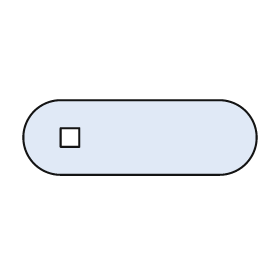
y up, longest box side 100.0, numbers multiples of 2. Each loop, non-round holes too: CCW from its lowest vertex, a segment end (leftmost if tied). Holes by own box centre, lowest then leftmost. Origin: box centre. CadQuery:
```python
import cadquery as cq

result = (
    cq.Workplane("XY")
    .moveTo(-34.0, -16.0)
    .lineTo(34.0, -16.0)
    .threePointArc((50.0, 0.0), (34.0, 16.0))
    .lineTo(-34.0, 16.0)
    .threePointArc((-50.0, 0.0), (-34.0, -16.0))
    .close()
    .moveTo(-34.0, -4.0)
    .lineTo(-26.0, -4.0)
    .lineTo(-26.0, 4.0)
    .lineTo(-34.0, 4.0)
    .close()
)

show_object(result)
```